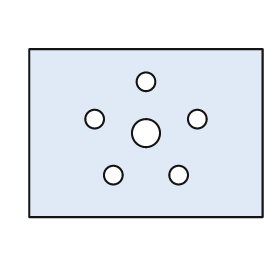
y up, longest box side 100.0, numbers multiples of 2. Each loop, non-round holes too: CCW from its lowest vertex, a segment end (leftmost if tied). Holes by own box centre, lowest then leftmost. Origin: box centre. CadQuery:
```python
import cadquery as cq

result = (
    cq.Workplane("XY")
    .moveTo(-50.0, -36.0)
    .lineTo(50.0, -36.0)
    .lineTo(50.0, 36.0)
    .lineTo(-50.0, 36.0)
    .close()
    .moveTo(-14.0, -18.0)
    .circle(4.0)
    .moveTo(14.0, -18.0)
    .circle(4.0)
    .moveTo(0.0, 0.0)
    .circle(6.0)
    .moveTo(-22.0, 6.0)
    .circle(4.0)
    .moveTo(22.0, 6.0)
    .circle(4.0)
    .moveTo(0.0, 22.0)
    .circle(4.0)
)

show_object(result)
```